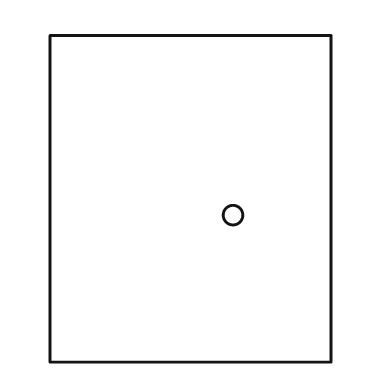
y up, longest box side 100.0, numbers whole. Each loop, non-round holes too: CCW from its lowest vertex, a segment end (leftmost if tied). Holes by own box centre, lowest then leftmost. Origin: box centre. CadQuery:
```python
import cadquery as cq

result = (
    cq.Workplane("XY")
    .moveTo(-43.0, -50.0)
    .lineTo(43.0, -50.0)
    .lineTo(43.0, 50.0)
    .lineTo(-43.0, 50.0)
    .close()
    .moveTo(13.0, -5.0)
    .circle(3.0)
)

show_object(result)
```